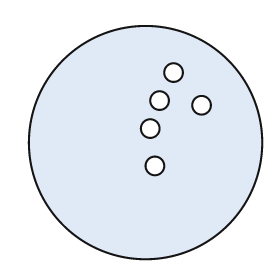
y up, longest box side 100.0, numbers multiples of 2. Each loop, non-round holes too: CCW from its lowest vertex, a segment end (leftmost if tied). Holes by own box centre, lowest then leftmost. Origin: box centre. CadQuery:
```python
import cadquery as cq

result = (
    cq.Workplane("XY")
    .moveTo(0.0, 0.0)
    .circle(50.0)
    .moveTo(4.0, -10.0)
    .circle(4.0)
    .moveTo(2.0, 6.0)
    .circle(4.0)
    .moveTo(24.0, 16.0)
    .circle(4.0)
    .moveTo(6.0, 18.0)
    .circle(4.0)
    .moveTo(12.0, 30.0)
    .circle(4.0)
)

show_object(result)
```